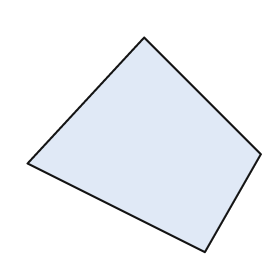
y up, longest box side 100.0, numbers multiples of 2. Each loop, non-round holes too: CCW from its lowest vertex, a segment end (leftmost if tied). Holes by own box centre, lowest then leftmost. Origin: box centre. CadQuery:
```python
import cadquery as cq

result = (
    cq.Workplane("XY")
    .moveTo(26.0, -46.0)
    .lineTo(50.0, -4.0)
    .lineTo(0.0, 46.0)
    .lineTo(-50.0, -8.0)
    .close()
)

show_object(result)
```